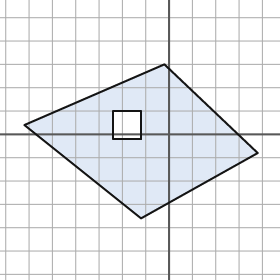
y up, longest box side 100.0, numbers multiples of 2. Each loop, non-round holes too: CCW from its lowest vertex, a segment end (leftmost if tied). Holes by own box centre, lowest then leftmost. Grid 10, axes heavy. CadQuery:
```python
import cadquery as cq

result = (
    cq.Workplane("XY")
    .moveTo(-12.0, -36.0)
    .lineTo(38.0, -8.0)
    .lineTo(-2.0, 30.0)
    .lineTo(-62.0, 4.0)
    .close()
    .moveTo(-24.0, -2.0)
    .lineTo(-12.0, -2.0)
    .lineTo(-12.0, 10.0)
    .lineTo(-24.0, 10.0)
    .close()
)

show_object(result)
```